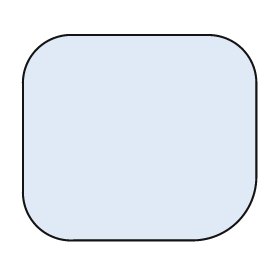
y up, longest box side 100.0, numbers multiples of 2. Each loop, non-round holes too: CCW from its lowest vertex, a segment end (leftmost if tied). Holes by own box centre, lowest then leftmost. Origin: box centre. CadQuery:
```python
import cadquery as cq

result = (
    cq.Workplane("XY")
    .moveTo(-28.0, -44.0)
    .lineTo(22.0, -44.0)
    .threePointArc((42.0, -36.0), (50.0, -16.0))
    .lineTo(50.0, 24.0)
    .threePointArc((44.0, 38.0), (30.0, 44.0))
    .lineTo(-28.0, 44.0)
    .threePointArc((-44.0, 38.0), (-50.0, 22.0))
    .lineTo(-50.0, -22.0)
    .threePointArc((-44.0, -38.0), (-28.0, -44.0))
    .close()
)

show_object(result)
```